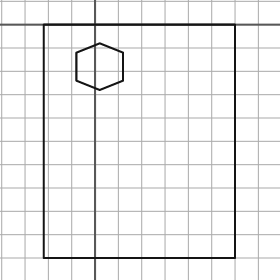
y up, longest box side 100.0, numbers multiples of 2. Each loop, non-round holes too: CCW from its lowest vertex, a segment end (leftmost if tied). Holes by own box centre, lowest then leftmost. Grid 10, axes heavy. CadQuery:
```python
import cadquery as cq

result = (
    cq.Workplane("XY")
    .moveTo(-22.0, -100.0)
    .lineTo(60.0, -100.0)
    .lineTo(60.0, 0.0)
    .lineTo(-22.0, 0.0)
    .close()
    .moveTo(2.0, -28.0)
    .lineTo(12.0, -24.0)
    .lineTo(12.0, -12.0)
    .lineTo(2.0, -8.0)
    .lineTo(-8.0, -12.0)
    .lineTo(-8.0, -24.0)
    .close()
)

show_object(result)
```